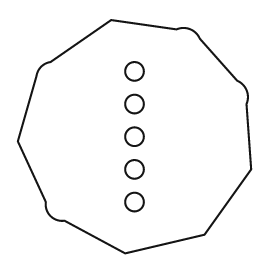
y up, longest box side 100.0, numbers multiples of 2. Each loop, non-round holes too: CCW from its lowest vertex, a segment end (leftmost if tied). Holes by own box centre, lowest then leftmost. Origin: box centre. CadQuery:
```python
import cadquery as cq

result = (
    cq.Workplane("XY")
    .moveTo(-4.0, -50.0)
    .lineTo(30.0, -42.0)
    .lineTo(50.0, -14.0)
    .lineTo(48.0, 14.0)
    .threePointArc((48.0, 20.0), (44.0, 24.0))
    .lineTo(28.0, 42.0)
    .threePointArc((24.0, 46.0), (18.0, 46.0))
    .lineTo(-10.0, 50.0)
    .lineTo(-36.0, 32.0)
    .threePointArc((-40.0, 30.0), (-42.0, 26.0))
    .lineTo(-50.0, -2.0)
    .lineTo(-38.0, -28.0)
    .threePointArc((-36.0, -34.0), (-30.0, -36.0))
    .close()
    .moveTo(0.0, -28.0)
    .circle(4.0)
    .moveTo(0.0, -14.0)
    .circle(4.0)
    .moveTo(0.0, 0.0)
    .circle(4.0)
    .moveTo(0.0, 14.0)
    .circle(4.0)
    .moveTo(0.0, 28.0)
    .circle(4.0)
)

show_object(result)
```